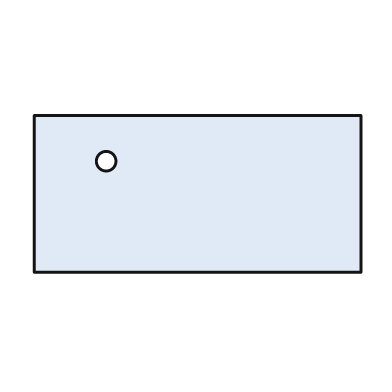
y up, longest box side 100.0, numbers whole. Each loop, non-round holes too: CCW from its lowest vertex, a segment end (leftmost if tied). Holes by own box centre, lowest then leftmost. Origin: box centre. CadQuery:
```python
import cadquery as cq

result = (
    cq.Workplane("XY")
    .moveTo(-50.0, -24.0)
    .lineTo(50.0, -24.0)
    .lineTo(50.0, 24.0)
    .lineTo(-50.0, 24.0)
    .close()
    .moveTo(-28.0, 10.0)
    .circle(3.0)
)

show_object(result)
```